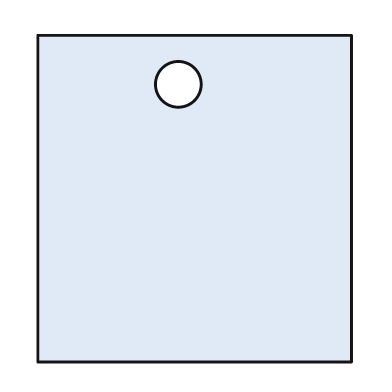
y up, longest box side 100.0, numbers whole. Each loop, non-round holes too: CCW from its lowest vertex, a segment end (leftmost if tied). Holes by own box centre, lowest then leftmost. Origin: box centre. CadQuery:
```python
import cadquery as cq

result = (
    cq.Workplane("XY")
    .moveTo(-48.0, -50.0)
    .lineTo(48.0, -50.0)
    .lineTo(48.0, 50.0)
    .lineTo(-48.0, 50.0)
    .close()
    .moveTo(-5.0, 35.0)
    .circle(7.0)
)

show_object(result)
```